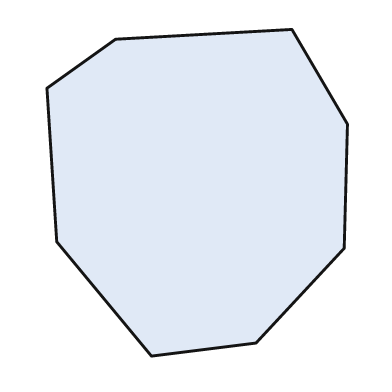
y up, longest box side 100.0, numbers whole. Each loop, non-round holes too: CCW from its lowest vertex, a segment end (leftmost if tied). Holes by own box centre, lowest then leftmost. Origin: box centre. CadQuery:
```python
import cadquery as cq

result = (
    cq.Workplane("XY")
    .moveTo(-14.0, -50.0)
    .lineTo(18.0, -46.0)
    .lineTo(45.0, -17.0)
    .lineTo(46.0, 21.0)
    .lineTo(29.0, 50.0)
    .lineTo(-25.0, 47.0)
    .lineTo(-46.0, 32.0)
    .lineTo(-43.0, -15.0)
    .close()
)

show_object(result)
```